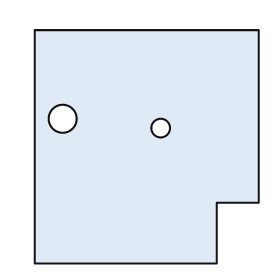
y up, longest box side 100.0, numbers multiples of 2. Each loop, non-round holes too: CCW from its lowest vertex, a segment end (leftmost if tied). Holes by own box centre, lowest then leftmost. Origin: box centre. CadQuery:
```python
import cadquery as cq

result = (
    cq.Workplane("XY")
    .moveTo(-48.0, -50.0)
    .lineTo(30.0, -50.0)
    .lineTo(30.0, -24.0)
    .lineTo(48.0, -24.0)
    .lineTo(48.0, 50.0)
    .lineTo(-48.0, 50.0)
    .close()
    .moveTo(6.0, 8.0)
    .circle(4.0)
    .moveTo(-36.0, 12.0)
    .circle(6.0)
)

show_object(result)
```